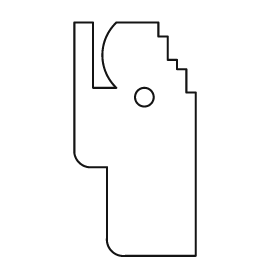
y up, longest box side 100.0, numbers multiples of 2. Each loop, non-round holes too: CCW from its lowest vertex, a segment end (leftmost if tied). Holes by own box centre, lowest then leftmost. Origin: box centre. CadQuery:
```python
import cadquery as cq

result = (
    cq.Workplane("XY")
    .moveTo(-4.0, -50.0)
    .lineTo(26.0, -50.0)
    .lineTo(26.0, 20.0)
    .lineTo(22.0, 20.0)
    .lineTo(22.0, 30.0)
    .lineTo(18.0, 30.0)
    .lineTo(18.0, 34.0)
    .lineTo(14.0, 34.0)
    .lineTo(14.0, 44.0)
    .lineTo(10.0, 44.0)
    .lineTo(10.0, 50.0)
    .lineTo(-8.0, 50.0)
    .threePointArc((-14.0, 36.0), (-8.0, 22.0))
    .lineTo(-18.0, 22.0)
    .lineTo(-18.0, 50.0)
    .lineTo(-26.0, 50.0)
    .lineTo(-26.0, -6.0)
    .threePointArc((-24.0, -10.0), (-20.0, -12.0))
    .lineTo(-12.0, -12.0)
    .lineTo(-12.0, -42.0)
    .threePointArc((-10.0, -48.0), (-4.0, -50.0))
    .close()
    .moveTo(4.0, 18.0)
    .circle(4.0)
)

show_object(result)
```